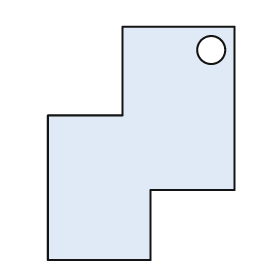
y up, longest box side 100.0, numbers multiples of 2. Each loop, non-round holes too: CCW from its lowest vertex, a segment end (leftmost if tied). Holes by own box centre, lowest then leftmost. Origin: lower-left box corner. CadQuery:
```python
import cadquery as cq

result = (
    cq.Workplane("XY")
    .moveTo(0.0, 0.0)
    .lineTo(44.0, 0.0)
    .lineTo(44.0, 30.0)
    .lineTo(80.0, 30.0)
    .lineTo(80.0, 100.0)
    .lineTo(32.0, 100.0)
    .lineTo(32.0, 62.0)
    .lineTo(0.0, 62.0)
    .close()
    .moveTo(70.0, 90.0)
    .circle(6.0)
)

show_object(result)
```